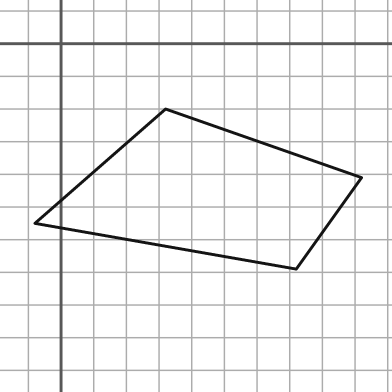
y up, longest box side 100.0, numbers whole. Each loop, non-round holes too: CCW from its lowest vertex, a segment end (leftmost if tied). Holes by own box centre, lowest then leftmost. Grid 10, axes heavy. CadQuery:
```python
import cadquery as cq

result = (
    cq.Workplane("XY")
    .moveTo(72.0, -69.0)
    .lineTo(92.0, -41.0)
    .lineTo(32.0, -20.0)
    .lineTo(-8.0, -55.0)
    .close()
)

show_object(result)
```